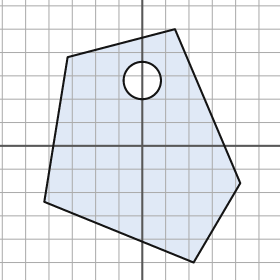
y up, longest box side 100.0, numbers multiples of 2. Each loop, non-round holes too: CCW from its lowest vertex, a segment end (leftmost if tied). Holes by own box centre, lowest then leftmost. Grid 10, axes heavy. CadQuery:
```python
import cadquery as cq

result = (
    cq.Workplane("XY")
    .moveTo(22.0, -50.0)
    .lineTo(42.0, -16.0)
    .lineTo(14.0, 50.0)
    .lineTo(-32.0, 38.0)
    .lineTo(-42.0, -24.0)
    .close()
    .moveTo(0.0, 28.0)
    .circle(8.0)
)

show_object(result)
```